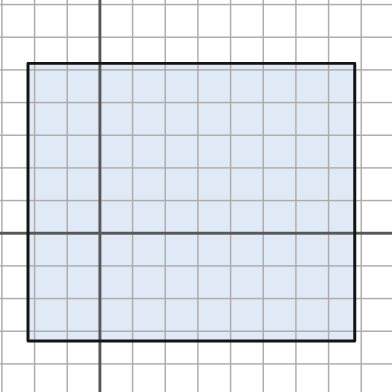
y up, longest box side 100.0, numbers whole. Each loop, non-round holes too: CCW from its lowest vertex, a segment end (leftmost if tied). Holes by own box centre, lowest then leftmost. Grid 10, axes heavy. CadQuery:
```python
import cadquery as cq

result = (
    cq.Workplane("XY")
    .moveTo(-22.0, -33.0)
    .lineTo(78.0, -33.0)
    .lineTo(78.0, 52.0)
    .lineTo(-22.0, 52.0)
    .close()
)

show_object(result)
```